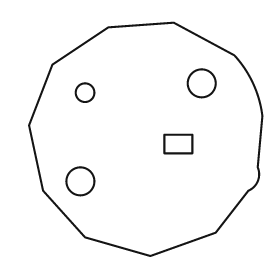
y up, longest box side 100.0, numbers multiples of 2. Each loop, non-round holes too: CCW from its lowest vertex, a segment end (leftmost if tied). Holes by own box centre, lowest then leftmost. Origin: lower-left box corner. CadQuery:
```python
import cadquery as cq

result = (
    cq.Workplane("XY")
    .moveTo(52.0, 0.0)
    .lineTo(80.0, 10.0)
    .lineTo(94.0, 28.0)
    .threePointArc((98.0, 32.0), (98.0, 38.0))
    .lineTo(100.0, 60.0)
    .threePointArc((96.0, 74.0), (88.0, 86.0))
    .lineTo(62.0, 100.0)
    .lineTo(34.0, 98.0)
    .lineTo(10.0, 82.0)
    .lineTo(0.0, 56.0)
    .lineTo(6.0, 28.0)
    .lineTo(24.0, 8.0)
    .close()
    .moveTo(22.0, 32.0)
    .circle(6.0)
    .moveTo(58.0, 44.0)
    .lineTo(70.0, 44.0)
    .lineTo(70.0, 52.0)
    .lineTo(58.0, 52.0)
    .close()
    .moveTo(24.0, 70.0)
    .circle(4.0)
    .moveTo(74.0, 74.0)
    .circle(6.0)
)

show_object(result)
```